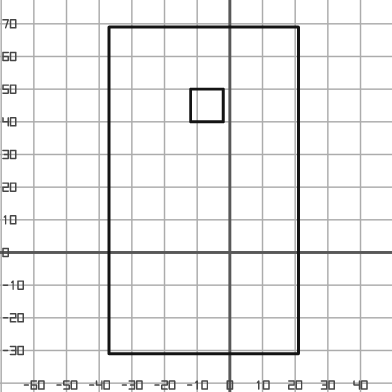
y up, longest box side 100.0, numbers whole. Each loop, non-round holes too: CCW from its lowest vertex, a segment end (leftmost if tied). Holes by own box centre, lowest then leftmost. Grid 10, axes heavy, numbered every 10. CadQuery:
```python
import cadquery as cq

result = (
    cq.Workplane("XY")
    .moveTo(-37.0, -31.0)
    .lineTo(21.0, -31.0)
    .lineTo(21.0, 69.0)
    .lineTo(-37.0, 69.0)
    .close()
    .moveTo(-12.0, 40.0)
    .lineTo(-2.0, 40.0)
    .lineTo(-2.0, 50.0)
    .lineTo(-12.0, 50.0)
    .close()
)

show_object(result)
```